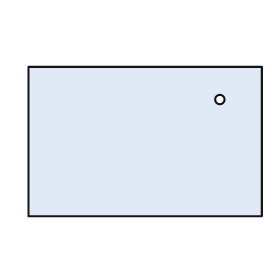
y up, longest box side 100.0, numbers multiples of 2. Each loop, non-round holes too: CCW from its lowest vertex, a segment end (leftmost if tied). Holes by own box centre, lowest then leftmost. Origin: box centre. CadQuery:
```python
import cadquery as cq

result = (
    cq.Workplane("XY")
    .moveTo(-50.0, -32.0)
    .lineTo(50.0, -32.0)
    .lineTo(50.0, 32.0)
    .lineTo(-50.0, 32.0)
    .close()
    .moveTo(32.0, 18.0)
    .circle(2.0)
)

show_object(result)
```